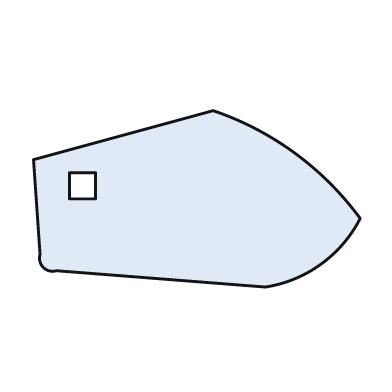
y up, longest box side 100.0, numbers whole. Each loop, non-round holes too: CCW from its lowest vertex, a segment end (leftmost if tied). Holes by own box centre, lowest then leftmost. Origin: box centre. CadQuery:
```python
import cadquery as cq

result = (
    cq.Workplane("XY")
    .moveTo(21.0, -27.0)
    .threePointArc((38.0, -20.0), (50.0, -6.0))
    .threePointArc((30.0, 14.0), (5.0, 27.0))
    .lineTo(-50.0, 12.0)
    .lineTo(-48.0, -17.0)
    .threePointArc((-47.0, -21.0), (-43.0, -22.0))
    .close()
    .moveTo(-39.0, 0.0)
    .lineTo(-31.0, 0.0)
    .lineTo(-31.0, 8.0)
    .lineTo(-39.0, 8.0)
    .close()
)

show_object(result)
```